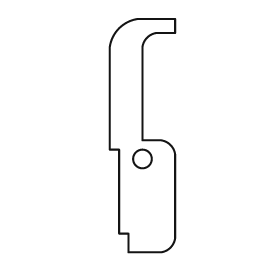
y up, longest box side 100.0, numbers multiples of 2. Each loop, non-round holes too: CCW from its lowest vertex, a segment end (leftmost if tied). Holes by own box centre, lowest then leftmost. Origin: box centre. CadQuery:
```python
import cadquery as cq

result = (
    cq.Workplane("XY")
    .moveTo(-6.0, -50.0)
    .lineTo(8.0, -50.0)
    .threePointArc((12.0, -48.0), (14.0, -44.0))
    .lineTo(14.0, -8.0)
    .threePointArc((12.0, -4.0), (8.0, -2.0))
    .lineTo(0.0, -2.0)
    .lineTo(0.0, 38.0)
    .threePointArc((2.0, 42.0), (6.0, 44.0))
    .lineTo(14.0, 44.0)
    .lineTo(14.0, 50.0)
    .lineTo(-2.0, 50.0)
    .threePointArc((-10.0, 46.0), (-14.0, 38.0))
    .lineTo(-14.0, -6.0)
    .lineTo(-10.0, -6.0)
    .lineTo(-10.0, -42.0)
    .lineTo(-6.0, -42.0)
    .close()
    .moveTo(0.0, -10.0)
    .circle(4.0)
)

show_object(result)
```